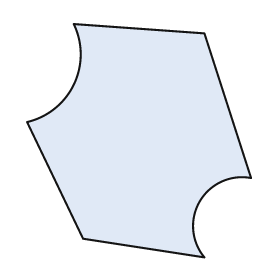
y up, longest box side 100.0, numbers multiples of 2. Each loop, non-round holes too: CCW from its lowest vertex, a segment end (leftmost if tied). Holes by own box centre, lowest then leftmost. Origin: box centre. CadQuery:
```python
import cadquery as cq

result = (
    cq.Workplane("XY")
    .moveTo(28.0, -50.0)
    .threePointArc((26.0, -26.0), (48.0, -16.0))
    .lineTo(28.0, 46.0)
    .lineTo(-28.0, 50.0)
    .threePointArc((-28.0, 24.0), (-48.0, 8.0))
    .lineTo(-24.0, -42.0)
    .close()
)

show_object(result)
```